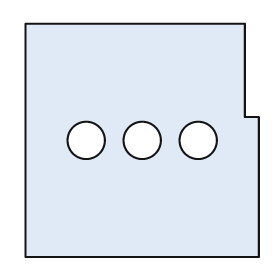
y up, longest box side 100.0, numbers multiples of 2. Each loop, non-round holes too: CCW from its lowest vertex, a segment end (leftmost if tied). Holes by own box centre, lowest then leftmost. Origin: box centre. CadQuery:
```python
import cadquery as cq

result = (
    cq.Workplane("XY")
    .moveTo(-50.0, -50.0)
    .lineTo(50.0, -50.0)
    .lineTo(50.0, 10.0)
    .lineTo(44.0, 10.0)
    .lineTo(44.0, 50.0)
    .lineTo(-50.0, 50.0)
    .close()
    .moveTo(-24.0, 0.0)
    .circle(8.0)
    .moveTo(0.0, 0.0)
    .circle(8.0)
    .moveTo(24.0, 0.0)
    .circle(8.0)
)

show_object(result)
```